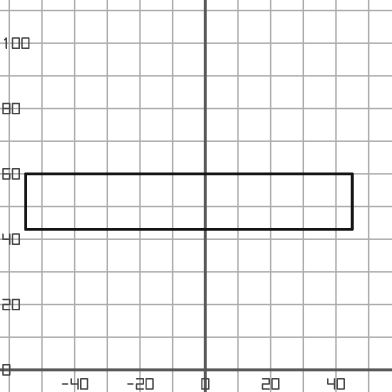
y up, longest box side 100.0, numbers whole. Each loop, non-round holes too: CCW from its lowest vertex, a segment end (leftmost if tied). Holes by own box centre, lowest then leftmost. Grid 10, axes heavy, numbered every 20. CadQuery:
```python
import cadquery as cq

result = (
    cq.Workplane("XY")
    .moveTo(-55.0, 43.0)
    .lineTo(45.0, 43.0)
    .lineTo(45.0, 60.0)
    .lineTo(-55.0, 60.0)
    .close()
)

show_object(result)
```